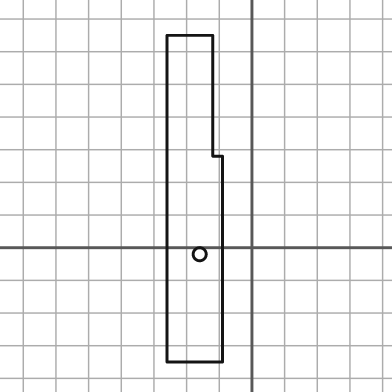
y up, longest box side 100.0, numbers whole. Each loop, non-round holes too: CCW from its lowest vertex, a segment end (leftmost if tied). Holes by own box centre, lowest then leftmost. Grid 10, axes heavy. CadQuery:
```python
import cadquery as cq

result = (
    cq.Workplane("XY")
    .moveTo(-26.0, -35.0)
    .lineTo(-9.0, -35.0)
    .lineTo(-9.0, 28.0)
    .lineTo(-12.0, 28.0)
    .lineTo(-12.0, 65.0)
    .lineTo(-26.0, 65.0)
    .close()
    .moveTo(-16.0, -2.0)
    .circle(2.0)
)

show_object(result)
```